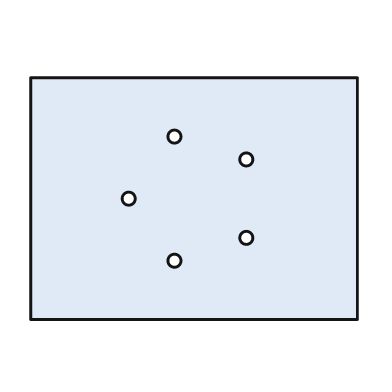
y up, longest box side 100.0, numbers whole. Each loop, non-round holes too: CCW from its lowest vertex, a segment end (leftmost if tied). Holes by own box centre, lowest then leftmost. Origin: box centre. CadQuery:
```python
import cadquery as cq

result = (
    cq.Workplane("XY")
    .moveTo(-50.0, -37.0)
    .lineTo(50.0, -37.0)
    .lineTo(50.0, 37.0)
    .lineTo(-50.0, 37.0)
    .close()
    .moveTo(-6.0, -19.0)
    .circle(2.0)
    .moveTo(16.0, -12.0)
    .circle(2.0)
    .moveTo(-20.0, 0.0)
    .circle(2.0)
    .moveTo(16.0, 12.0)
    .circle(2.0)
    .moveTo(-6.0, 19.0)
    .circle(2.0)
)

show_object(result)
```